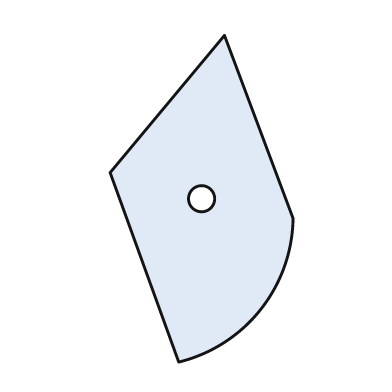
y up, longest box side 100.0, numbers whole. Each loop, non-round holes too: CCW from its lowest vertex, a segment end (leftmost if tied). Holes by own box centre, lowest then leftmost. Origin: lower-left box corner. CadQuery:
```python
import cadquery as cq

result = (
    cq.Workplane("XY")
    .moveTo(21.0, 0.0)
    .threePointArc((46.0, 16.0), (56.0, 44.0))
    .lineTo(35.0, 100.0)
    .lineTo(0.0, 58.0)
    .close()
    .moveTo(28.0, 50.0)
    .circle(4.0)
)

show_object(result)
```